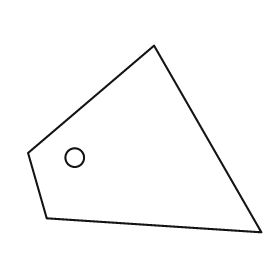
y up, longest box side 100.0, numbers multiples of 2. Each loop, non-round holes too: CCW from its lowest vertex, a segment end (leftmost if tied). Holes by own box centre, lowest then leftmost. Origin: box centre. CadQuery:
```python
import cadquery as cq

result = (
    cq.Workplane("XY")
    .moveTo(50.0, -40.0)
    .lineTo(4.0, 40.0)
    .lineTo(-50.0, -6.0)
    .lineTo(-42.0, -34.0)
    .close()
    .moveTo(-30.0, -8.0)
    .circle(4.0)
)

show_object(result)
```